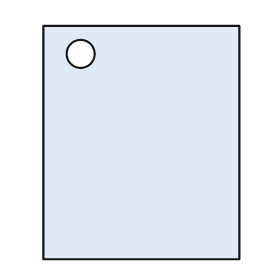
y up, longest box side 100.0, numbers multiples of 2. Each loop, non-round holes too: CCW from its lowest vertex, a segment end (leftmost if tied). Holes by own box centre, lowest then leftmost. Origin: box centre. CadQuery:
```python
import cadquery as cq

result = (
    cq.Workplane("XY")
    .moveTo(-42.0, -50.0)
    .lineTo(42.0, -50.0)
    .lineTo(42.0, 50.0)
    .lineTo(-42.0, 50.0)
    .close()
    .moveTo(-26.0, 38.0)
    .circle(6.0)
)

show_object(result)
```